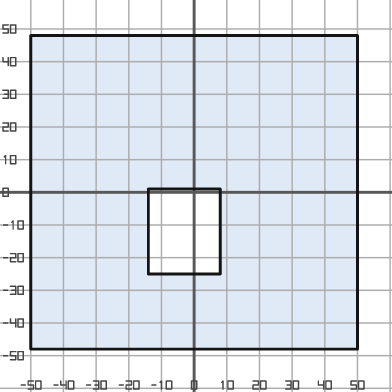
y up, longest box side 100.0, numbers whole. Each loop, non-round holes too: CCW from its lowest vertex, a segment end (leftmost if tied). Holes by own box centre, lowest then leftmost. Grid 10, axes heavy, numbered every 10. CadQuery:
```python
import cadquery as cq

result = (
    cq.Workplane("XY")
    .moveTo(-50.0, -48.0)
    .lineTo(50.0, -48.0)
    .lineTo(50.0, 48.0)
    .lineTo(-50.0, 48.0)
    .close()
    .moveTo(-14.0, -25.0)
    .lineTo(8.0, -25.0)
    .lineTo(8.0, 1.0)
    .lineTo(-14.0, 1.0)
    .close()
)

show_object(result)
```